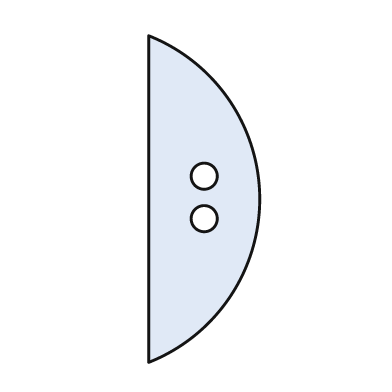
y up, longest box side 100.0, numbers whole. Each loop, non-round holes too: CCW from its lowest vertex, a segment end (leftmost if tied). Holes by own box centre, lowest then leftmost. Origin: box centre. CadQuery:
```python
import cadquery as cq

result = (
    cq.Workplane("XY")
    .moveTo(-17.0, -50.0)
    .threePointArc((17.0, 0.0), (-17.0, 50.0))
    .close()
    .moveTo(0.0, -6.0)
    .circle(4.0)
    .moveTo(0.0, 7.0)
    .circle(4.0)
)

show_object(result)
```